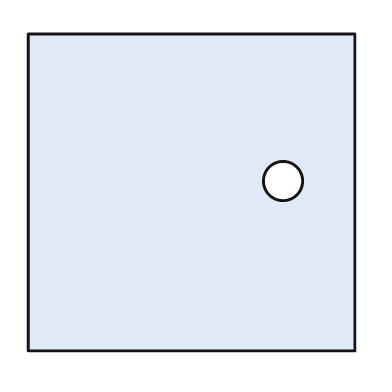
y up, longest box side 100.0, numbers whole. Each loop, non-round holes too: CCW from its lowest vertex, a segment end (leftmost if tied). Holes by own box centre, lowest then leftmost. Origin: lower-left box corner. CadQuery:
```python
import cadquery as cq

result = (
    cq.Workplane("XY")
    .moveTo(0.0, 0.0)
    .lineTo(100.0, 0.0)
    .lineTo(100.0, 97.0)
    .lineTo(0.0, 97.0)
    .close()
    .moveTo(78.0, 52.0)
    .circle(6.0)
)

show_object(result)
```